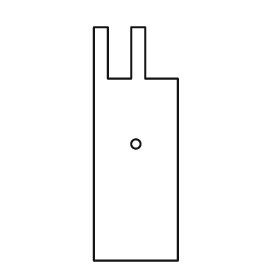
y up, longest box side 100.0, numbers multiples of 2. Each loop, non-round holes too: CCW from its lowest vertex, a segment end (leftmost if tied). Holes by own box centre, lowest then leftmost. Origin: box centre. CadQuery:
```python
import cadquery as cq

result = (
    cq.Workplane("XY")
    .moveTo(-18.0, -50.0)
    .lineTo(18.0, -50.0)
    .lineTo(18.0, 28.0)
    .lineTo(4.0, 28.0)
    .lineTo(4.0, 50.0)
    .lineTo(-2.0, 50.0)
    .lineTo(-2.0, 28.0)
    .lineTo(-12.0, 28.0)
    .lineTo(-12.0, 50.0)
    .lineTo(-18.0, 50.0)
    .close()
    .moveTo(0.0, 0.0)
    .circle(2.0)
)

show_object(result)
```